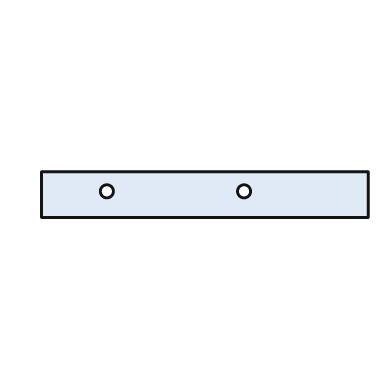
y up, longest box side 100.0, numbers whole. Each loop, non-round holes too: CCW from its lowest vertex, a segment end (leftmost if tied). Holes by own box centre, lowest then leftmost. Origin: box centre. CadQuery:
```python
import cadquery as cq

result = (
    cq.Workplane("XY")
    .moveTo(-50.0, -7.0)
    .lineTo(50.0, -7.0)
    .lineTo(50.0, 7.0)
    .lineTo(-50.0, 7.0)
    .close()
    .moveTo(-30.0, 1.0)
    .circle(2.0)
    .moveTo(12.0, 1.0)
    .circle(2.0)
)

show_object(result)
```